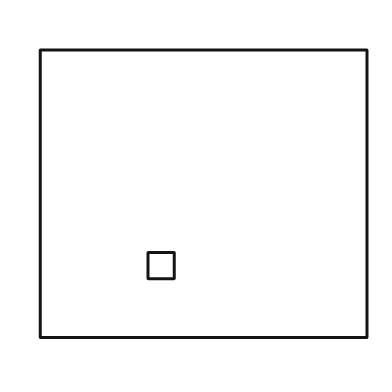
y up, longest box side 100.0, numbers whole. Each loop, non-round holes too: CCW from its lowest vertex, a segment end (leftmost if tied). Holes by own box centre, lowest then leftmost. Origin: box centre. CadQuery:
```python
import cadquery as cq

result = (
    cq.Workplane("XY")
    .moveTo(-50.0, -44.0)
    .lineTo(50.0, -44.0)
    .lineTo(50.0, 44.0)
    .lineTo(-50.0, 44.0)
    .close()
    .moveTo(-17.0, -26.0)
    .lineTo(-9.0, -26.0)
    .lineTo(-9.0, -18.0)
    .lineTo(-17.0, -18.0)
    .close()
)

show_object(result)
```